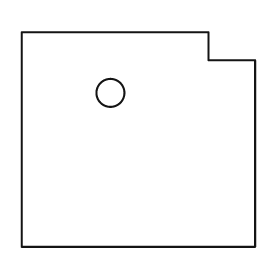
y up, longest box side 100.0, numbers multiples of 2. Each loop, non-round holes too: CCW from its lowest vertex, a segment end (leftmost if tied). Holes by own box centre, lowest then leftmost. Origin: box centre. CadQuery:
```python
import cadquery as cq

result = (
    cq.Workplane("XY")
    .moveTo(-50.0, -46.0)
    .lineTo(50.0, -46.0)
    .lineTo(50.0, 34.0)
    .lineTo(30.0, 34.0)
    .lineTo(30.0, 46.0)
    .lineTo(-50.0, 46.0)
    .close()
    .moveTo(-12.0, 20.0)
    .circle(6.0)
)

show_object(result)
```